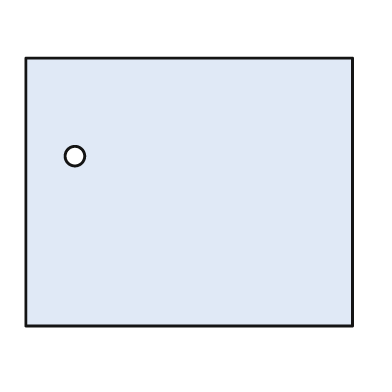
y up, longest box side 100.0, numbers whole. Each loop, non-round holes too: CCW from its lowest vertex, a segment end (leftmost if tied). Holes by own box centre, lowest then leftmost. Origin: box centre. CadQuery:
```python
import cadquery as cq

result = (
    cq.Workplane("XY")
    .moveTo(-50.0, -41.0)
    .lineTo(50.0, -41.0)
    .lineTo(50.0, 41.0)
    .lineTo(-50.0, 41.0)
    .close()
    .moveTo(-35.0, 11.0)
    .circle(3.0)
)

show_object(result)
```